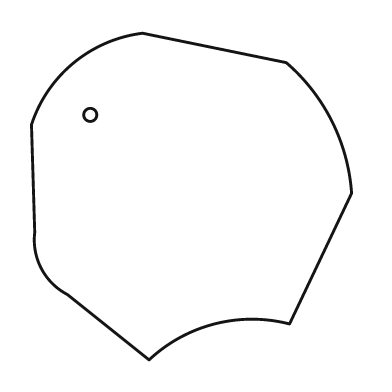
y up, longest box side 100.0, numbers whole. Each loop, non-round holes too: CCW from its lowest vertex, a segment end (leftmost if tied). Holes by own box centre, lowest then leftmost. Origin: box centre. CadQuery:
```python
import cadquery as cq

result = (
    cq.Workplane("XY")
    .moveTo(-13.0, -50.0)
    .threePointArc((7.0, -39.0), (30.0, -39.0))
    .lineTo(49.0, 1.0)
    .threePointArc((43.0, 23.0), (29.0, 41.0))
    .lineTo(-15.0, 50.0)
    .threePointArc((-36.0, 41.0), (-49.0, 22.0))
    .lineTo(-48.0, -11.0)
    .threePointArc((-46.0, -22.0), (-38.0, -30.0))
    .close()
    .moveTo(-31.0, 25.0)
    .circle(2.0)
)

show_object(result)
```